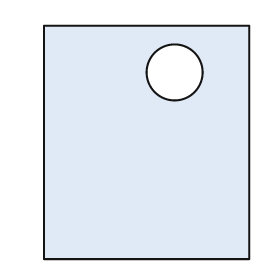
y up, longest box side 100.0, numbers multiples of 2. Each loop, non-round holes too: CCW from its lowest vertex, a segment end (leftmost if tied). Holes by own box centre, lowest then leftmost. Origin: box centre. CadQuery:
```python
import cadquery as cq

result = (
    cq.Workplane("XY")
    .moveTo(-44.0, -50.0)
    .lineTo(44.0, -50.0)
    .lineTo(44.0, 50.0)
    .lineTo(-44.0, 50.0)
    .close()
    .moveTo(12.0, 30.0)
    .circle(12.0)
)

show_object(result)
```